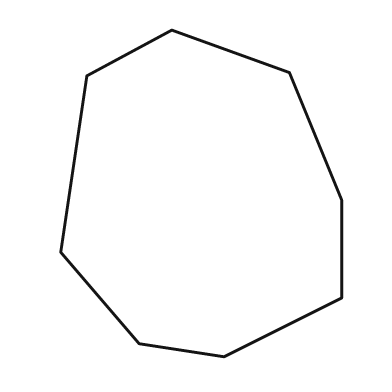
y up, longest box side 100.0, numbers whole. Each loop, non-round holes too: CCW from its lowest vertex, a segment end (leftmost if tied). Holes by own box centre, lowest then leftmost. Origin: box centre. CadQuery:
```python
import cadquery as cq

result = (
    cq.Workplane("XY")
    .moveTo(7.0, -50.0)
    .lineTo(43.0, -32.0)
    .lineTo(43.0, -2.0)
    .lineTo(27.0, 37.0)
    .lineTo(-9.0, 50.0)
    .lineTo(-35.0, 36.0)
    .lineTo(-43.0, -18.0)
    .lineTo(-19.0, -46.0)
    .close()
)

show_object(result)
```